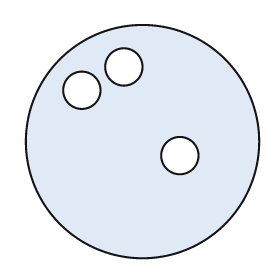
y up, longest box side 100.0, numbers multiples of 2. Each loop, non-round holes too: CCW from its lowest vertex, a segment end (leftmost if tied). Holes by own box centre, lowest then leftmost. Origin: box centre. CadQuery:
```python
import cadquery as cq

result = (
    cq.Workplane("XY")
    .moveTo(0.0, 0.0)
    .circle(50.0)
    .moveTo(16.0, -6.0)
    .circle(8.0)
    .moveTo(-26.0, 22.0)
    .circle(8.0)
    .moveTo(-8.0, 32.0)
    .circle(8.0)
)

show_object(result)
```